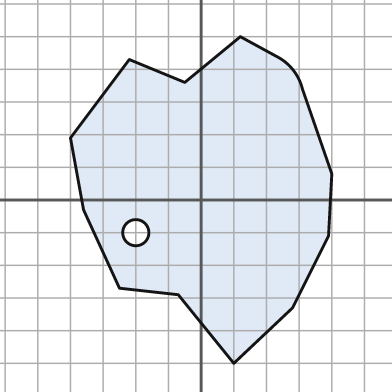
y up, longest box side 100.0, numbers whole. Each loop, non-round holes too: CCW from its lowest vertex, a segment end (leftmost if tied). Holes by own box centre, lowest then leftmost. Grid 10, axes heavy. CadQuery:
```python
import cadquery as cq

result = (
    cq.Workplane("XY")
    .moveTo(10.0, -50.0)
    .lineTo(28.0, -33.0)
    .lineTo(39.0, -11.0)
    .lineTo(40.0, 8.0)
    .lineTo(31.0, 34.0)
    .threePointArc((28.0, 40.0), (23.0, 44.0))
    .lineTo(12.0, 50.0)
    .lineTo(-5.0, 36.0)
    .lineTo(-22.0, 43.0)
    .lineTo(-40.0, 19.0)
    .lineTo(-36.0, -3.0)
    .lineTo(-25.0, -27.0)
    .lineTo(-7.0, -29.0)
    .close()
    .moveTo(-20.0, -10.0)
    .circle(4.0)
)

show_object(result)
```